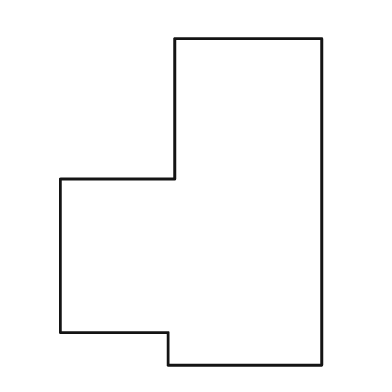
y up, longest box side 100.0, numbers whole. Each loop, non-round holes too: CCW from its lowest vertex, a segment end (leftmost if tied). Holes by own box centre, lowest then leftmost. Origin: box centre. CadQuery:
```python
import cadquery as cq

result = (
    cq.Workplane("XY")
    .moveTo(-7.0, -50.0)
    .lineTo(40.0, -50.0)
    .lineTo(40.0, 50.0)
    .lineTo(-5.0, 50.0)
    .lineTo(-5.0, 7.0)
    .lineTo(-40.0, 7.0)
    .lineTo(-40.0, -40.0)
    .lineTo(-7.0, -40.0)
    .close()
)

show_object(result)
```